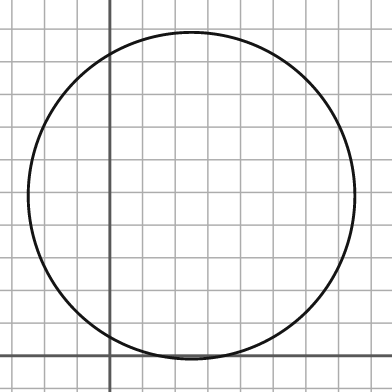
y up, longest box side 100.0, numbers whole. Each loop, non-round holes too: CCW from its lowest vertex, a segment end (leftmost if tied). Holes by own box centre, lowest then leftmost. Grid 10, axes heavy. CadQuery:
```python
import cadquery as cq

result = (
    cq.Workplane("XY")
    .moveTo(25.0, 49.0)
    .circle(50.0)
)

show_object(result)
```